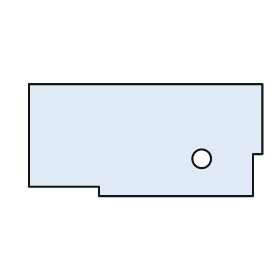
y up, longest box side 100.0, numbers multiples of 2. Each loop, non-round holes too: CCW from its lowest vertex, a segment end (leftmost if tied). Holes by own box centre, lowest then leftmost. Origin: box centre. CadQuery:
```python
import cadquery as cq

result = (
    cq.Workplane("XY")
    .moveTo(-20.0, -24.0)
    .lineTo(46.0, -24.0)
    .lineTo(46.0, -6.0)
    .lineTo(50.0, -6.0)
    .lineTo(50.0, 24.0)
    .lineTo(-50.0, 24.0)
    .lineTo(-50.0, -20.0)
    .lineTo(-20.0, -20.0)
    .close()
    .moveTo(24.0, -8.0)
    .circle(4.0)
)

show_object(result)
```